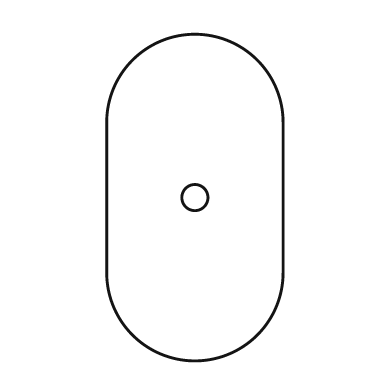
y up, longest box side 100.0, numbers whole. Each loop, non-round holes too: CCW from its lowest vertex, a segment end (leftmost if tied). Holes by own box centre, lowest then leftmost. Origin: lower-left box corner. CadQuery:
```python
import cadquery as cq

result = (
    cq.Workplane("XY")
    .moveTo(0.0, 27.0)
    .threePointArc((27.0, 0.0), (54.0, 27.0))
    .lineTo(54.0, 73.0)
    .threePointArc((27.0, 100.0), (0.0, 73.0))
    .close()
    .moveTo(27.0, 50.0)
    .circle(4.0)
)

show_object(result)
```